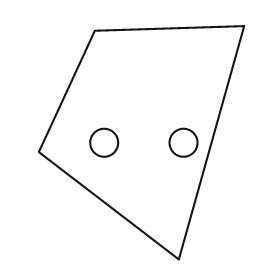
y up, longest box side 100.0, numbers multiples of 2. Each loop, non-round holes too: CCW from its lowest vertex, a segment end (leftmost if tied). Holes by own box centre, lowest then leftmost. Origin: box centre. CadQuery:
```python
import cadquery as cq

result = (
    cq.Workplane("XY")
    .moveTo(16.0, -50.0)
    .lineTo(44.0, 50.0)
    .lineTo(-20.0, 48.0)
    .lineTo(-44.0, -4.0)
    .close()
    .moveTo(-16.0, 0.0)
    .circle(6.0)
    .moveTo(18.0, 0.0)
    .circle(6.0)
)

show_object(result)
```